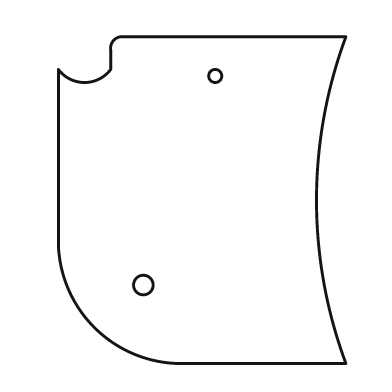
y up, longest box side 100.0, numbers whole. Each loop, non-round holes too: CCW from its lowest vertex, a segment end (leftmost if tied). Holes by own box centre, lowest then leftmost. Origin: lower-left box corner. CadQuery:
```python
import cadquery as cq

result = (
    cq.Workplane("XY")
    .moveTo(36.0, 0.0)
    .lineTo(88.0, 0.0)
    .threePointArc((79.0, 50.0), (88.0, 100.0))
    .lineTo(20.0, 100.0)
    .threePointArc((17.0, 99.0), (16.0, 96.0))
    .lineTo(16.0, 90.0)
    .threePointArc((8.0, 86.0), (0.0, 90.0))
    .lineTo(0.0, 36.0)
    .threePointArc((11.0, 11.0), (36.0, 0.0))
    .close()
    .moveTo(26.0, 24.0)
    .circle(3.0)
    .moveTo(48.0, 88.0)
    .circle(2.0)
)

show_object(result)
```